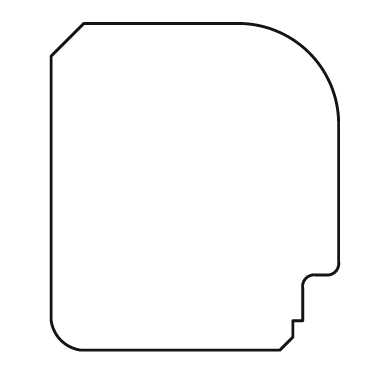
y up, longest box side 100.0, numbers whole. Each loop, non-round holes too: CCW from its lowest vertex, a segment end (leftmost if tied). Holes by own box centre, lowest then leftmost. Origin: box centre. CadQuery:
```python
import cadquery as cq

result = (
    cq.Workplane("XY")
    .moveTo(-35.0, -50.0)
    .lineTo(26.0, -50.0)
    .lineTo(30.0, -46.0)
    .lineTo(30.0, -41.0)
    .lineTo(33.0, -41.0)
    .lineTo(33.0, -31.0)
    .threePointArc((34.0, -28.0), (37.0, -27.0))
    .lineTo(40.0, -27.0)
    .threePointArc((43.0, -26.0), (44.0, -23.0))
    .lineTo(44.0, 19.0)
    .threePointArc((35.0, 41.0), (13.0, 50.0))
    .lineTo(-34.0, 50.0)
    .lineTo(-44.0, 40.0)
    .lineTo(-44.0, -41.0)
    .threePointArc((-41.0, -47.0), (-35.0, -50.0))
    .close()
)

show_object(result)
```